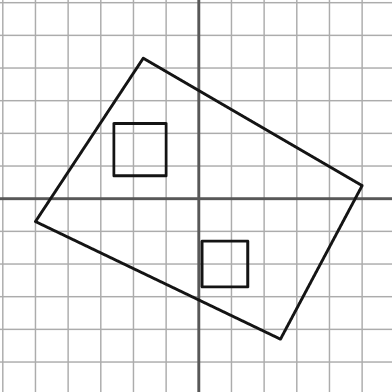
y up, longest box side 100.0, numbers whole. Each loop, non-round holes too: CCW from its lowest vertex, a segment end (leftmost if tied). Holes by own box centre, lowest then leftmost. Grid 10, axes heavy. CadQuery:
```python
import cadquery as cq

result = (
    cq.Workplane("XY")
    .moveTo(25.0, -43.0)
    .lineTo(50.0, 4.0)
    .lineTo(-17.0, 43.0)
    .lineTo(-50.0, -7.0)
    .close()
    .moveTo(1.0, -27.0)
    .lineTo(15.0, -27.0)
    .lineTo(15.0, -13.0)
    .lineTo(1.0, -13.0)
    .close()
    .moveTo(-26.0, 7.0)
    .lineTo(-10.0, 7.0)
    .lineTo(-10.0, 23.0)
    .lineTo(-26.0, 23.0)
    .close()
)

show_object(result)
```